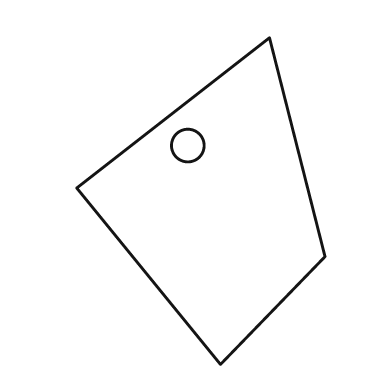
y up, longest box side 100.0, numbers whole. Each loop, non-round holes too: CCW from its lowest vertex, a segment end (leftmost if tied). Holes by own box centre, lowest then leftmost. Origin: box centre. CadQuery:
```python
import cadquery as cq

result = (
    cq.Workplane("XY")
    .moveTo(6.0, -50.0)
    .lineTo(38.0, -17.0)
    .lineTo(21.0, 50.0)
    .lineTo(-38.0, 4.0)
    .close()
    .moveTo(-4.0, 17.0)
    .circle(5.0)
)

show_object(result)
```